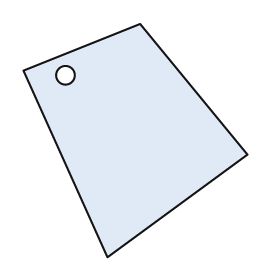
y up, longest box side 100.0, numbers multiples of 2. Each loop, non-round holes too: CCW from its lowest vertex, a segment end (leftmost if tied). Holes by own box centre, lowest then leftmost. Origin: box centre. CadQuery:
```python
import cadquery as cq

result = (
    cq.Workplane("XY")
    .moveTo(-12.0, -50.0)
    .lineTo(48.0, -6.0)
    .lineTo(2.0, 50.0)
    .lineTo(-48.0, 30.0)
    .close()
    .moveTo(-30.0, 28.0)
    .circle(4.0)
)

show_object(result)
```